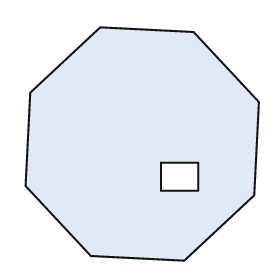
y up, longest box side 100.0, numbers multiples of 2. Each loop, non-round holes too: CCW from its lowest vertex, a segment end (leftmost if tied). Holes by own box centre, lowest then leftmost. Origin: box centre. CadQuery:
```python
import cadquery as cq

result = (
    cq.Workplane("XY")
    .moveTo(18.0, -50.0)
    .lineTo(48.0, -22.0)
    .lineTo(50.0, 18.0)
    .lineTo(22.0, 48.0)
    .lineTo(-18.0, 50.0)
    .lineTo(-48.0, 22.0)
    .lineTo(-50.0, -18.0)
    .lineTo(-22.0, -48.0)
    .close()
    .moveTo(8.0, -20.0)
    .lineTo(24.0, -20.0)
    .lineTo(24.0, -8.0)
    .lineTo(8.0, -8.0)
    .close()
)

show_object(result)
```